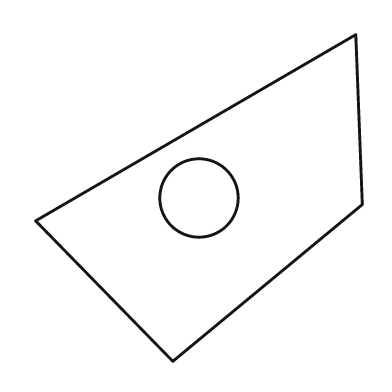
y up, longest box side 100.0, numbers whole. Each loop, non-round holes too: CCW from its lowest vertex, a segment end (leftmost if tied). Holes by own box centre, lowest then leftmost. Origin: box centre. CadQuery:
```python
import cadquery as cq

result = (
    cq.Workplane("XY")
    .moveTo(-8.0, -50.0)
    .lineTo(50.0, -2.0)
    .lineTo(48.0, 50.0)
    .lineTo(-50.0, -7.0)
    .close()
    .moveTo(0.0, 0.0)
    .circle(12.0)
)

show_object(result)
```